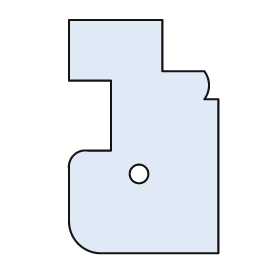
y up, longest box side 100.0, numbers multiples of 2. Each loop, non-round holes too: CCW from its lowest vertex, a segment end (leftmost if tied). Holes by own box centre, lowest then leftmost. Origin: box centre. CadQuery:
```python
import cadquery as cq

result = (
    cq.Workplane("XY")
    .moveTo(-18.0, -50.0)
    .lineTo(32.0, -50.0)
    .lineTo(32.0, 16.0)
    .lineTo(26.0, 16.0)
    .threePointArc((28.0, 22.0), (26.0, 28.0))
    .lineTo(8.0, 28.0)
    .lineTo(8.0, 50.0)
    .lineTo(-32.0, 50.0)
    .lineTo(-32.0, 24.0)
    .lineTo(-14.0, 24.0)
    .lineTo(-14.0, -6.0)
    .lineTo(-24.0, -6.0)
    .threePointArc((-30.0, -8.0), (-32.0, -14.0))
    .lineTo(-32.0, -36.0)
    .threePointArc((-28.0, -46.0), (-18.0, -50.0))
    .close()
    .moveTo(-2.0, -16.0)
    .circle(4.0)
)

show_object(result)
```